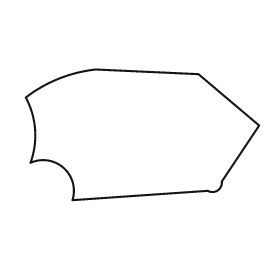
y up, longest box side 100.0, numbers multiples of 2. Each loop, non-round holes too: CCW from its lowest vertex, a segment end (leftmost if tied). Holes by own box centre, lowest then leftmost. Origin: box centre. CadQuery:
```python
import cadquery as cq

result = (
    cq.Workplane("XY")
    .moveTo(-30.0, -28.0)
    .lineTo(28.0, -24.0)
    .threePointArc((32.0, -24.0), (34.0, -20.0))
    .lineTo(50.0, 4.0)
    .lineTo(24.0, 26.0)
    .lineTo(-20.0, 28.0)
    .threePointArc((-36.0, 24.0), (-50.0, 16.0))
    .threePointArc((-46.0, 2.0), (-48.0, -12.0))
    .threePointArc((-34.0, -14.0), (-30.0, -28.0))
    .close()
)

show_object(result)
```